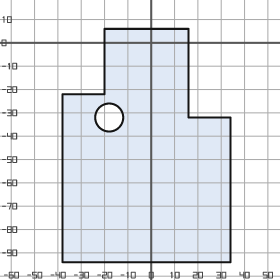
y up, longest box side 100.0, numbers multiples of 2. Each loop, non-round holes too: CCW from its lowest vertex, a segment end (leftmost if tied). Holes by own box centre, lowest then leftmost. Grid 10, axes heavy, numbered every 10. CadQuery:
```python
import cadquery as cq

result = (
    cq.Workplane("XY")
    .moveTo(-38.0, -94.0)
    .lineTo(34.0, -94.0)
    .lineTo(34.0, -32.0)
    .lineTo(16.0, -32.0)
    .lineTo(16.0, 6.0)
    .lineTo(-20.0, 6.0)
    .lineTo(-20.0, -22.0)
    .lineTo(-38.0, -22.0)
    .close()
    .moveTo(-18.0, -32.0)
    .circle(6.0)
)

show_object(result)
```